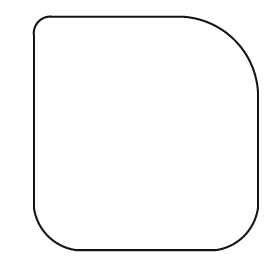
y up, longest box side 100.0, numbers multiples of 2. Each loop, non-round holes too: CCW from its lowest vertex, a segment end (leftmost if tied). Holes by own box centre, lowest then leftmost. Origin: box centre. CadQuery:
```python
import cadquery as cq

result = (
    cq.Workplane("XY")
    .moveTo(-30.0, -50.0)
    .lineTo(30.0, -50.0)
    .threePointArc((42.0, -44.0), (48.0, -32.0))
    .lineTo(48.0, 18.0)
    .threePointArc((38.0, 40.0), (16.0, 50.0))
    .lineTo(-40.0, 50.0)
    .threePointArc((-46.0, 48.0), (-48.0, 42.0))
    .lineTo(-48.0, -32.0)
    .threePointArc((-42.0, -44.0), (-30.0, -50.0))
    .close()
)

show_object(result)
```